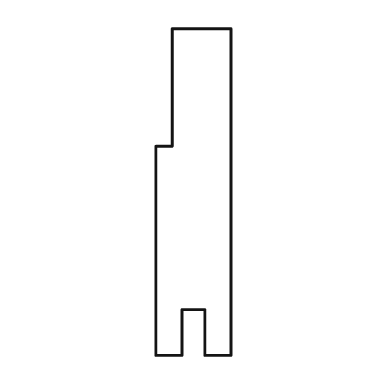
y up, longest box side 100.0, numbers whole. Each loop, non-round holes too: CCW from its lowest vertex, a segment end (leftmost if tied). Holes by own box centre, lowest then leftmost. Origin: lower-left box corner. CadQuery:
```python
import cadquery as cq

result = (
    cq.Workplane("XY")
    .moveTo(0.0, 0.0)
    .lineTo(8.0, 0.0)
    .lineTo(8.0, 14.0)
    .lineTo(15.0, 14.0)
    .lineTo(15.0, 0.0)
    .lineTo(23.0, 0.0)
    .lineTo(23.0, 100.0)
    .lineTo(5.0, 100.0)
    .lineTo(5.0, 64.0)
    .lineTo(0.0, 64.0)
    .close()
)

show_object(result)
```